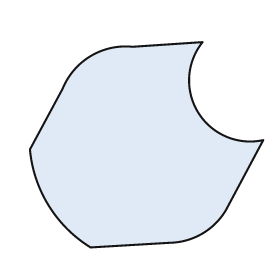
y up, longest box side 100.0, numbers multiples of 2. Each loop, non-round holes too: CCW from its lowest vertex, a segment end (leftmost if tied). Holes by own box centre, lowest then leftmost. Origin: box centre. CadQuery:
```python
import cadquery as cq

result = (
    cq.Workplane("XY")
    .moveTo(-24.0, -44.0)
    .lineTo(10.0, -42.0)
    .threePointArc((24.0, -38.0), (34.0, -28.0))
    .lineTo(50.0, 2.0)
    .threePointArc((22.0, 14.0), (24.0, 44.0))
    .lineTo(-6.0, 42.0)
    .threePointArc((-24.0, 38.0), (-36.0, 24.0))
    .lineTo(-50.0, -2.0)
    .threePointArc((-42.0, -26.0), (-24.0, -44.0))
    .close()
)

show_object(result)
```